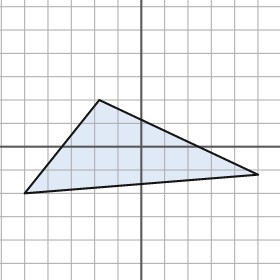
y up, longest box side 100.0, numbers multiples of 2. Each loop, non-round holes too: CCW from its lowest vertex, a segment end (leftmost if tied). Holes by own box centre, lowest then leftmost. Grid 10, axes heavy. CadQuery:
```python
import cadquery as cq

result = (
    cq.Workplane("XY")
    .moveTo(-50.0, -20.0)
    .lineTo(50.0, -12.0)
    .lineTo(-18.0, 20.0)
    .close()
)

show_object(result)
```